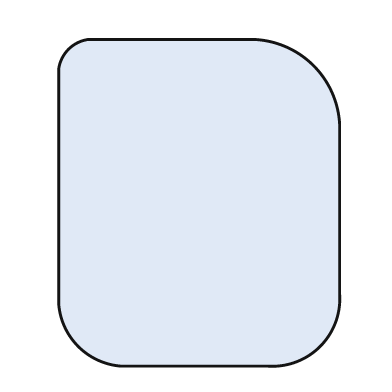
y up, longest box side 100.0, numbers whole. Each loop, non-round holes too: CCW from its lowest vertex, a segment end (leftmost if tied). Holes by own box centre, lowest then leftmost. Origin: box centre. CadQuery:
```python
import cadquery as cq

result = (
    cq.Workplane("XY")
    .moveTo(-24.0, -50.0)
    .lineTo(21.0, -50.0)
    .threePointArc((37.0, -44.0), (43.0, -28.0))
    .lineTo(43.0, 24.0)
    .threePointArc((35.0, 42.0), (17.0, 50.0))
    .lineTo(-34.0, 50.0)
    .threePointArc((-40.0, 47.0), (-43.0, 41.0))
    .lineTo(-43.0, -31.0)
    .threePointArc((-37.0, -44.0), (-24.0, -50.0))
    .close()
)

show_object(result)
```